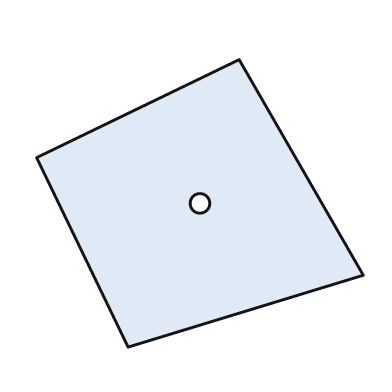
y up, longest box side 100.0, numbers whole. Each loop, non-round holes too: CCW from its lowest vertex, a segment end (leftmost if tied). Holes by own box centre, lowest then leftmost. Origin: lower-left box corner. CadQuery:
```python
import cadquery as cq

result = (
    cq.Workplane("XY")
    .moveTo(28.0, 0.0)
    .lineTo(100.0, 22.0)
    .lineTo(62.0, 88.0)
    .lineTo(0.0, 58.0)
    .close()
    .moveTo(50.0, 44.0)
    .circle(3.0)
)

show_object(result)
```